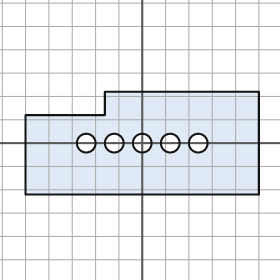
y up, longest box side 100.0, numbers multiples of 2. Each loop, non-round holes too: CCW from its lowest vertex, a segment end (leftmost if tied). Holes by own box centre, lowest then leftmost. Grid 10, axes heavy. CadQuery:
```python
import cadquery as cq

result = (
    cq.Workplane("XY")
    .moveTo(-50.0, -22.0)
    .lineTo(50.0, -22.0)
    .lineTo(50.0, 22.0)
    .lineTo(-16.0, 22.0)
    .lineTo(-16.0, 12.0)
    .lineTo(-50.0, 12.0)
    .close()
    .moveTo(-24.0, 0.0)
    .circle(4.0)
    .moveTo(-12.0, 0.0)
    .circle(4.0)
    .moveTo(0.0, 0.0)
    .circle(4.0)
    .moveTo(12.0, 0.0)
    .circle(4.0)
    .moveTo(24.0, 0.0)
    .circle(4.0)
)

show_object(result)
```